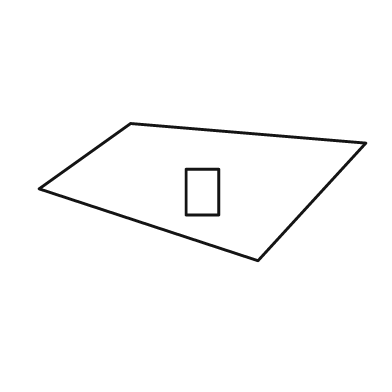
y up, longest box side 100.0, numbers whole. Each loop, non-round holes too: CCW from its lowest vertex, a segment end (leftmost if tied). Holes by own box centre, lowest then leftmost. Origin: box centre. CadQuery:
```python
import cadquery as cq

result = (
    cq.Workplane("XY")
    .moveTo(17.0, -21.0)
    .lineTo(50.0, 15.0)
    .lineTo(-22.0, 21.0)
    .lineTo(-50.0, 1.0)
    .close()
    .moveTo(-5.0, -7.0)
    .lineTo(5.0, -7.0)
    .lineTo(5.0, 7.0)
    .lineTo(-5.0, 7.0)
    .close()
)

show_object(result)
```